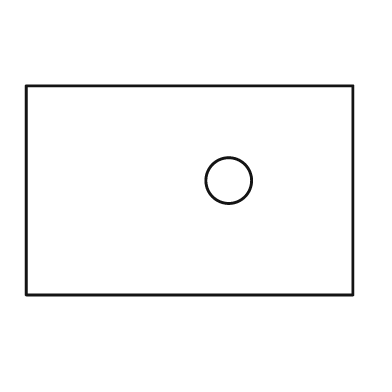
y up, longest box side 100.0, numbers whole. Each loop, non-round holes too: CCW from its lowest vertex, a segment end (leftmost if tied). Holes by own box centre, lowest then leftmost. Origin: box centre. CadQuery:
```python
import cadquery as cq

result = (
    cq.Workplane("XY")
    .moveTo(-50.0, -32.0)
    .lineTo(50.0, -32.0)
    .lineTo(50.0, 32.0)
    .lineTo(-50.0, 32.0)
    .close()
    .moveTo(12.0, 3.0)
    .circle(7.0)
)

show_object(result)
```